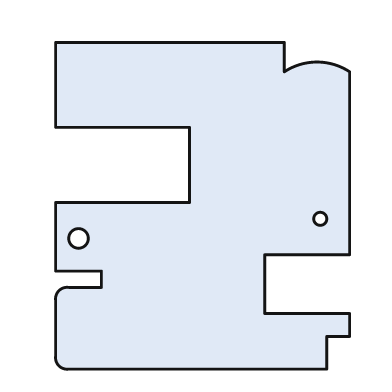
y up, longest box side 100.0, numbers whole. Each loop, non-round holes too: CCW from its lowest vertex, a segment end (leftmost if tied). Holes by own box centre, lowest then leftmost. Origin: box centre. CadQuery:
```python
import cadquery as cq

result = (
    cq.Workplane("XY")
    .moveTo(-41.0, -50.0)
    .lineTo(38.0, -50.0)
    .lineTo(38.0, -40.0)
    .lineTo(45.0, -40.0)
    .lineTo(45.0, -33.0)
    .lineTo(19.0, -33.0)
    .lineTo(19.0, -15.0)
    .lineTo(45.0, -15.0)
    .lineTo(45.0, 41.0)
    .threePointArc((35.0, 44.0), (25.0, 41.0))
    .lineTo(25.0, 50.0)
    .lineTo(-45.0, 50.0)
    .lineTo(-45.0, 24.0)
    .lineTo(-4.0, 24.0)
    .lineTo(-4.0, 1.0)
    .lineTo(-45.0, 1.0)
    .lineTo(-45.0, -20.0)
    .lineTo(-31.0, -20.0)
    .lineTo(-31.0, -25.0)
    .lineTo(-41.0, -25.0)
    .threePointArc((-44.0, -26.0), (-45.0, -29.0))
    .lineTo(-45.0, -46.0)
    .threePointArc((-44.0, -49.0), (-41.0, -50.0))
    .close()
    .moveTo(-38.0, -10.0)
    .circle(3.0)
    .moveTo(36.0, -4.0)
    .circle(2.0)
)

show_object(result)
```